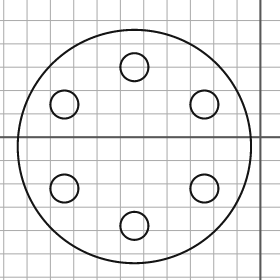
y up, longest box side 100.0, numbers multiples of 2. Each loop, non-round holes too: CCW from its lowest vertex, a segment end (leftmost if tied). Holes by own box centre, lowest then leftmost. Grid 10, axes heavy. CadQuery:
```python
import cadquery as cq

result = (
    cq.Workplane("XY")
    .moveTo(-54.0, -4.0)
    .circle(50.0)
    .moveTo(-54.0, -38.0)
    .circle(6.0)
    .moveTo(-84.0, -22.0)
    .circle(6.0)
    .moveTo(-24.0, -22.0)
    .circle(6.0)
    .moveTo(-84.0, 14.0)
    .circle(6.0)
    .moveTo(-24.0, 14.0)
    .circle(6.0)
    .moveTo(-54.0, 30.0)
    .circle(6.0)
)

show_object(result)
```